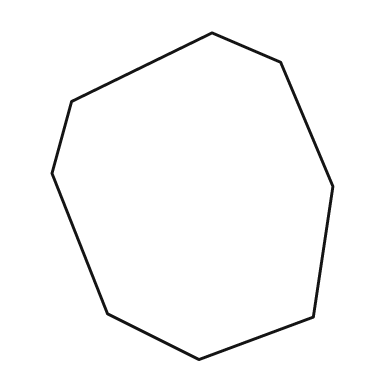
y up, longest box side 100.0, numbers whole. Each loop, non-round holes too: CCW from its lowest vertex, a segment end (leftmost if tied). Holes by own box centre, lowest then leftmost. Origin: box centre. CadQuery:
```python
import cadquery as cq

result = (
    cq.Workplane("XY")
    .moveTo(2.0, -50.0)
    .lineTo(37.0, -37.0)
    .lineTo(43.0, 3.0)
    .lineTo(27.0, 41.0)
    .lineTo(6.0, 50.0)
    .lineTo(-37.0, 29.0)
    .lineTo(-43.0, 7.0)
    .lineTo(-26.0, -36.0)
    .close()
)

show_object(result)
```